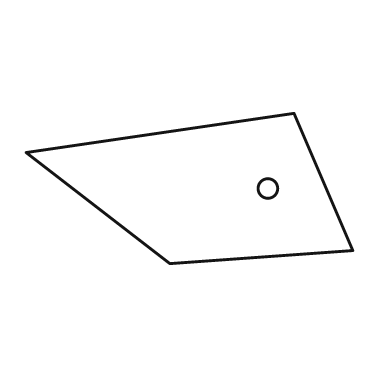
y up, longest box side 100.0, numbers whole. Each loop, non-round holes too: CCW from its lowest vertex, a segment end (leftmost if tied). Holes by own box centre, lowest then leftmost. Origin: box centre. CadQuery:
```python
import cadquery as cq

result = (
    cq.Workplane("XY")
    .moveTo(-6.0, -23.0)
    .lineTo(50.0, -19.0)
    .lineTo(32.0, 23.0)
    .lineTo(-50.0, 11.0)
    .close()
    .moveTo(24.0, 0.0)
    .circle(3.0)
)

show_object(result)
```